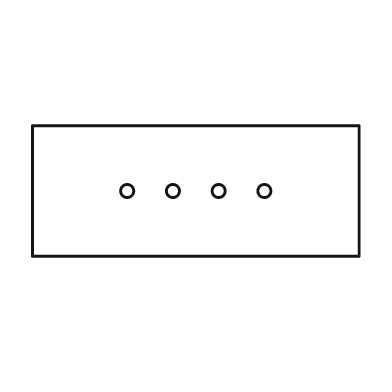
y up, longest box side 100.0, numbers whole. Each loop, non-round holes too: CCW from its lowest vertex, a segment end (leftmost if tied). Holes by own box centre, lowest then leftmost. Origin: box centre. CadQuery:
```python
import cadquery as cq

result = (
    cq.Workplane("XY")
    .moveTo(-50.0, -20.0)
    .lineTo(50.0, -20.0)
    .lineTo(50.0, 20.0)
    .lineTo(-50.0, 20.0)
    .close()
    .moveTo(-21.0, 0.0)
    .circle(2.0)
    .moveTo(-7.0, 0.0)
    .circle(2.0)
    .moveTo(7.0, 0.0)
    .circle(2.0)
    .moveTo(21.0, 0.0)
    .circle(2.0)
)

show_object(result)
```